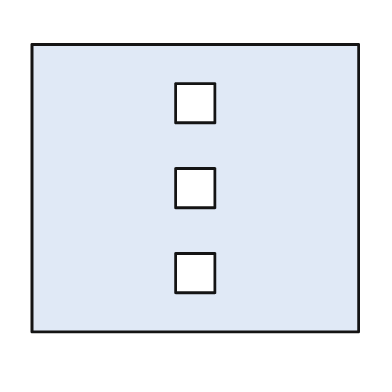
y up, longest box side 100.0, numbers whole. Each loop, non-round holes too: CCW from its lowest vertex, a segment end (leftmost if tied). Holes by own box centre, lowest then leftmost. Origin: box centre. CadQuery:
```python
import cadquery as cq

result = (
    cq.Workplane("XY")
    .moveTo(-50.0, -44.0)
    .lineTo(50.0, -44.0)
    .lineTo(50.0, 44.0)
    .lineTo(-50.0, 44.0)
    .close()
    .moveTo(-6.0, -32.0)
    .lineTo(6.0, -32.0)
    .lineTo(6.0, -20.0)
    .lineTo(-6.0, -20.0)
    .close()
    .moveTo(-6.0, -6.0)
    .lineTo(6.0, -6.0)
    .lineTo(6.0, 6.0)
    .lineTo(-6.0, 6.0)
    .close()
    .moveTo(-6.0, 20.0)
    .lineTo(6.0, 20.0)
    .lineTo(6.0, 32.0)
    .lineTo(-6.0, 32.0)
    .close()
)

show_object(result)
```